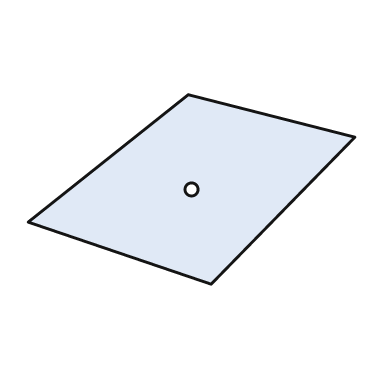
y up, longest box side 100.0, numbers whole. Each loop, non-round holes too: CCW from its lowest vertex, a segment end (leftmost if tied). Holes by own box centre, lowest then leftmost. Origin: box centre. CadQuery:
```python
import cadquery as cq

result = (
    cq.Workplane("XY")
    .moveTo(6.0, -29.0)
    .lineTo(50.0, 16.0)
    .lineTo(-1.0, 29.0)
    .lineTo(-50.0, -10.0)
    .close()
    .moveTo(0.0, 0.0)
    .circle(2.0)
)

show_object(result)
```